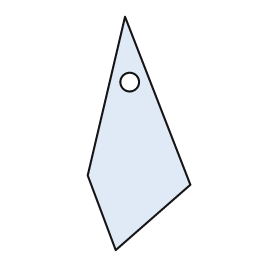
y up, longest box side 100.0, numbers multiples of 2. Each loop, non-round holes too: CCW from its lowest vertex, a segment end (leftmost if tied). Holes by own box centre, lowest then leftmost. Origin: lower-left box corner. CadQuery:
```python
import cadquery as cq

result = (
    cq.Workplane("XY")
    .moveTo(12.0, 0.0)
    .lineTo(44.0, 28.0)
    .lineTo(16.0, 100.0)
    .lineTo(0.0, 32.0)
    .close()
    .moveTo(18.0, 72.0)
    .circle(4.0)
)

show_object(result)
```